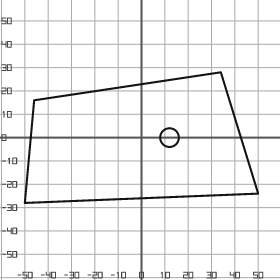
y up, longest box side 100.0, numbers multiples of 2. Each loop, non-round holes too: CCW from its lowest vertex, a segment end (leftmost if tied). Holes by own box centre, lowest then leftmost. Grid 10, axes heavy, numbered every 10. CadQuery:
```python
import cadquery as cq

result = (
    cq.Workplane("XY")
    .moveTo(-50.0, -28.0)
    .lineTo(50.0, -24.0)
    .lineTo(34.0, 28.0)
    .lineTo(-46.0, 16.0)
    .close()
    .moveTo(12.0, 0.0)
    .circle(4.0)
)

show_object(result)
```